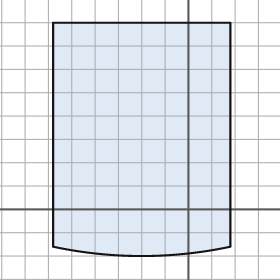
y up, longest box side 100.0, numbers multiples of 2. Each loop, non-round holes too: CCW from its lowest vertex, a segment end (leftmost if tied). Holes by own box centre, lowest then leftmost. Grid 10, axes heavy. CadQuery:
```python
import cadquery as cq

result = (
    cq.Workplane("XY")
    .moveTo(-58.0, -16.0)
    .threePointArc((-20.0, -20.0), (18.0, -16.0))
    .lineTo(18.0, 80.0)
    .lineTo(-58.0, 80.0)
    .close()
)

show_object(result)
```